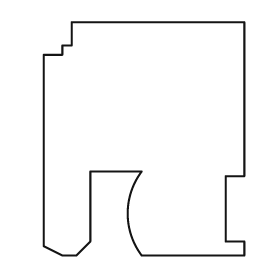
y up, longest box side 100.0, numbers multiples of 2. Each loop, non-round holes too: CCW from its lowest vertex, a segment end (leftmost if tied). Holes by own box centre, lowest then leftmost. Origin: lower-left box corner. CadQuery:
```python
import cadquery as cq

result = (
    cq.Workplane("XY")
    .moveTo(8.0, 0.0)
    .lineTo(14.0, 0.0)
    .lineTo(20.0, 6.0)
    .lineTo(20.0, 36.0)
    .lineTo(42.0, 36.0)
    .threePointArc((36.0, 18.0), (42.0, 0.0))
    .lineTo(86.0, 0.0)
    .lineTo(86.0, 6.0)
    .lineTo(78.0, 6.0)
    .lineTo(78.0, 34.0)
    .lineTo(86.0, 34.0)
    .lineTo(86.0, 100.0)
    .lineTo(12.0, 100.0)
    .lineTo(12.0, 90.0)
    .lineTo(8.0, 90.0)
    .lineTo(8.0, 86.0)
    .lineTo(0.0, 86.0)
    .lineTo(0.0, 4.0)
    .close()
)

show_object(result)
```